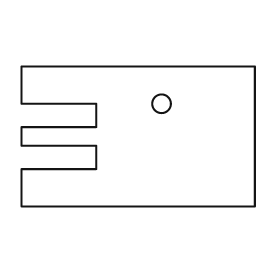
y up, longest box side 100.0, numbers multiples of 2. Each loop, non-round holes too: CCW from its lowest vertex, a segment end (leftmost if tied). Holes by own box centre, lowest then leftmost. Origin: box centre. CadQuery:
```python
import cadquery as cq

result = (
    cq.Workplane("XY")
    .moveTo(-50.0, -30.0)
    .lineTo(50.0, -30.0)
    .lineTo(50.0, 30.0)
    .lineTo(-50.0, 30.0)
    .lineTo(-50.0, 14.0)
    .lineTo(-18.0, 14.0)
    .lineTo(-18.0, 4.0)
    .lineTo(-50.0, 4.0)
    .lineTo(-50.0, -4.0)
    .lineTo(-18.0, -4.0)
    .lineTo(-18.0, -14.0)
    .lineTo(-50.0, -14.0)
    .close()
    .moveTo(10.0, 14.0)
    .circle(4.0)
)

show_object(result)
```